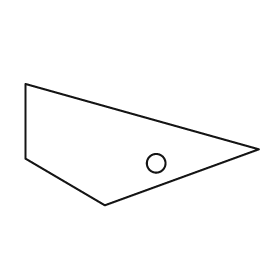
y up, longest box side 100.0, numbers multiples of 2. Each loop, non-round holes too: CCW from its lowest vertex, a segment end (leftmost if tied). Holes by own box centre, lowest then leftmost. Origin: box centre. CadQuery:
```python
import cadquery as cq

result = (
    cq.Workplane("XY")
    .moveTo(-16.0, -26.0)
    .lineTo(50.0, -2.0)
    .lineTo(-50.0, 26.0)
    .lineTo(-50.0, -6.0)
    .close()
    .moveTo(6.0, -8.0)
    .circle(4.0)
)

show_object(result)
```